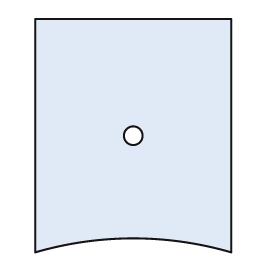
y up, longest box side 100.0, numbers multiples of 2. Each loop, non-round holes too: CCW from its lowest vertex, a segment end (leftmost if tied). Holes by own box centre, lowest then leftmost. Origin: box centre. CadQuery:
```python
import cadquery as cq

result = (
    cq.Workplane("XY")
    .moveTo(-42.0, -50.0)
    .threePointArc((0.0, -44.0), (42.0, -50.0))
    .lineTo(42.0, 50.0)
    .lineTo(-42.0, 50.0)
    .close()
    .moveTo(0.0, 0.0)
    .circle(4.0)
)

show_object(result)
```